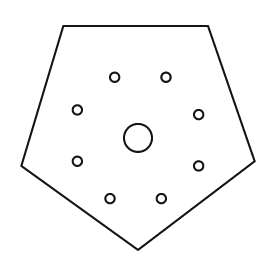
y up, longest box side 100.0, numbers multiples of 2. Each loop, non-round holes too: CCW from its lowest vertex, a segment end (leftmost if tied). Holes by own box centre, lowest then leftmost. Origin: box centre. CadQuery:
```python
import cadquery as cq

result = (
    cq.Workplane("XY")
    .moveTo(0.0, -48.0)
    .lineTo(50.0, -10.0)
    .lineTo(30.0, 48.0)
    .lineTo(-32.0, 48.0)
    .lineTo(-50.0, -12.0)
    .close()
    .moveTo(-12.0, -26.0)
    .circle(2.0)
    .moveTo(10.0, -26.0)
    .circle(2.0)
    .moveTo(26.0, -12.0)
    .circle(2.0)
    .moveTo(-26.0, -10.0)
    .circle(2.0)
    .moveTo(0.0, 0.0)
    .circle(6.0)
    .moveTo(26.0, 10.0)
    .circle(2.0)
    .moveTo(-26.0, 12.0)
    .circle(2.0)
    .moveTo(-10.0, 26.0)
    .circle(2.0)
    .moveTo(12.0, 26.0)
    .circle(2.0)
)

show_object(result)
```